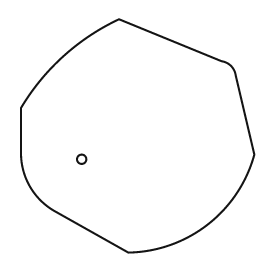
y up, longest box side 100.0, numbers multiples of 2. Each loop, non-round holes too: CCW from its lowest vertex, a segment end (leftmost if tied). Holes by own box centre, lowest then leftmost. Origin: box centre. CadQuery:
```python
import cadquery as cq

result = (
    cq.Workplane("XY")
    .moveTo(-4.0, -50.0)
    .threePointArc((30.0, -38.0), (50.0, -8.0))
    .lineTo(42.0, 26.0)
    .threePointArc((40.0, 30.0), (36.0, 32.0))
    .lineTo(-8.0, 50.0)
    .threePointArc((-32.0, 34.0), (-50.0, 12.0))
    .lineTo(-50.0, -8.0)
    .threePointArc((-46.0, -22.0), (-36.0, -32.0))
    .close()
    .moveTo(-24.0, -10.0)
    .circle(2.0)
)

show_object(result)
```